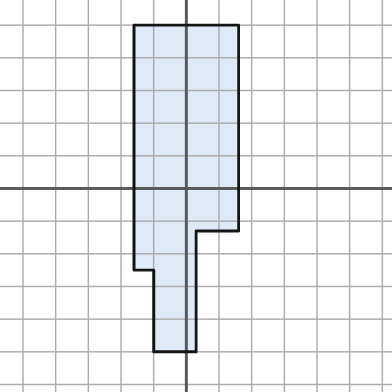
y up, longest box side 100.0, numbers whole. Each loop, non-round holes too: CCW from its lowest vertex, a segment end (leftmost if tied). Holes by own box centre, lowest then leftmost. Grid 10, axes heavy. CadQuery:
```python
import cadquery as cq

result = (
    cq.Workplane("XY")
    .moveTo(-10.0, -50.0)
    .lineTo(3.0, -50.0)
    .lineTo(3.0, -13.0)
    .lineTo(16.0, -13.0)
    .lineTo(16.0, 50.0)
    .lineTo(-16.0, 50.0)
    .lineTo(-16.0, -25.0)
    .lineTo(-10.0, -25.0)
    .close()
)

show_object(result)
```